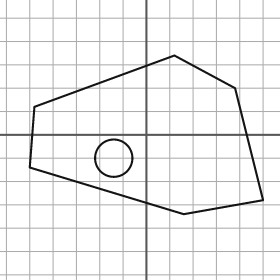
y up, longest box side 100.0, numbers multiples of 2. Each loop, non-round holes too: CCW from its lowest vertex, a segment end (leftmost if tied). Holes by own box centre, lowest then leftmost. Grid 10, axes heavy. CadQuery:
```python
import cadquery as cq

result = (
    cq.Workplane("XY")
    .moveTo(16.0, -34.0)
    .lineTo(50.0, -28.0)
    .lineTo(38.0, 20.0)
    .lineTo(12.0, 34.0)
    .lineTo(-48.0, 12.0)
    .lineTo(-50.0, -14.0)
    .close()
    .moveTo(-14.0, -10.0)
    .circle(8.0)
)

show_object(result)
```